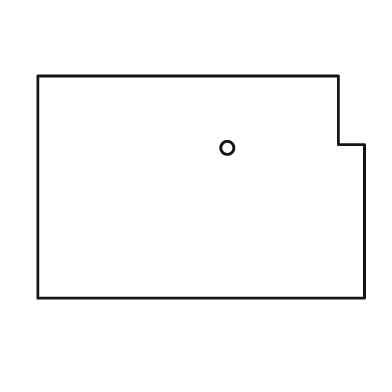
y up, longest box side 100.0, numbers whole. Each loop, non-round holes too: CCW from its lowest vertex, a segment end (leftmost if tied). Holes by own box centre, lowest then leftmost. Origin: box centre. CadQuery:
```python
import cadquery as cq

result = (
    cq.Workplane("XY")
    .moveTo(-50.0, -34.0)
    .lineTo(50.0, -34.0)
    .lineTo(50.0, 13.0)
    .lineTo(42.0, 13.0)
    .lineTo(42.0, 34.0)
    .lineTo(-50.0, 34.0)
    .close()
    .moveTo(8.0, 12.0)
    .circle(2.0)
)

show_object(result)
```